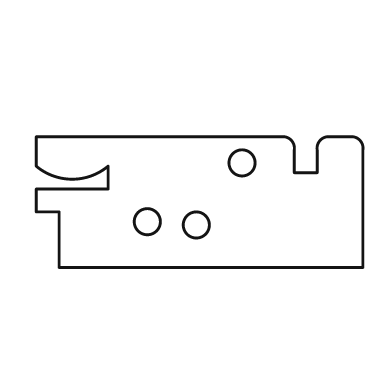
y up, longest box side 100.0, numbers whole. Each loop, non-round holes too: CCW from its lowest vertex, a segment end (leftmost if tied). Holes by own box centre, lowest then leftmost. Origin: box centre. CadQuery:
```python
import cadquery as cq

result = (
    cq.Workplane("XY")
    .moveTo(-43.0, -20.0)
    .lineTo(50.0, -20.0)
    .lineTo(50.0, 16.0)
    .threePointArc((49.0, 19.0), (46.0, 20.0))
    .lineTo(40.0, 20.0)
    .threePointArc((37.0, 19.0), (36.0, 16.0))
    .lineTo(36.0, 9.0)
    .lineTo(29.0, 9.0)
    .lineTo(29.0, 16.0)
    .threePointArc((28.0, 19.0), (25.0, 20.0))
    .lineTo(-50.0, 20.0)
    .lineTo(-50.0, 11.0)
    .threePointArc((-39.0, 7.0), (-28.0, 11.0))
    .lineTo(-28.0, 4.0)
    .lineTo(-50.0, 4.0)
    .lineTo(-50.0, -3.0)
    .lineTo(-43.0, -3.0)
    .close()
    .moveTo(-1.0, -7.0)
    .circle(4.0)
    .moveTo(-16.0, -6.0)
    .circle(4.0)
    .moveTo(13.0, 12.0)
    .circle(4.0)
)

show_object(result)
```